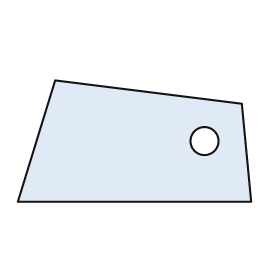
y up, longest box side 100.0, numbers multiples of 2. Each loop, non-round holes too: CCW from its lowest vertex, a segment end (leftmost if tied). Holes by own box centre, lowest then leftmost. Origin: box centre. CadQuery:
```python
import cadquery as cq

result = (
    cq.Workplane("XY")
    .moveTo(-50.0, -26.0)
    .lineTo(50.0, -26.0)
    .lineTo(46.0, 16.0)
    .lineTo(-34.0, 26.0)
    .close()
    .moveTo(30.0, 0.0)
    .circle(6.0)
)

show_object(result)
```